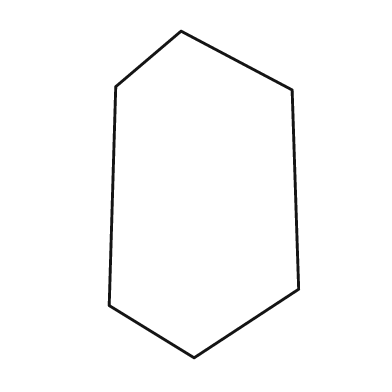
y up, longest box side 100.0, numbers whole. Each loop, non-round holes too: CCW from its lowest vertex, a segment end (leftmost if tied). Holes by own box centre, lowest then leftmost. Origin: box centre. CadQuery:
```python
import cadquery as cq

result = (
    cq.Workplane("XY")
    .moveTo(-3.0, -50.0)
    .lineTo(29.0, -29.0)
    .lineTo(27.0, 32.0)
    .lineTo(-7.0, 50.0)
    .lineTo(-27.0, 33.0)
    .lineTo(-29.0, -34.0)
    .close()
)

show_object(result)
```